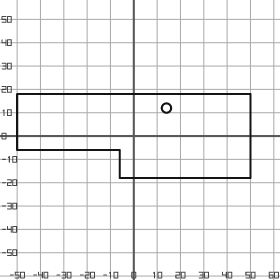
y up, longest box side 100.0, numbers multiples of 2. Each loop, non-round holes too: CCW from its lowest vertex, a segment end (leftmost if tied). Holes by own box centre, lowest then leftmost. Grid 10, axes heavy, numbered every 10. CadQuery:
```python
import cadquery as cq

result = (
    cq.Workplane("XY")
    .moveTo(-6.0, -18.0)
    .lineTo(50.0, -18.0)
    .lineTo(50.0, 18.0)
    .lineTo(-50.0, 18.0)
    .lineTo(-50.0, -6.0)
    .lineTo(-6.0, -6.0)
    .close()
    .moveTo(14.0, 12.0)
    .circle(2.0)
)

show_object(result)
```